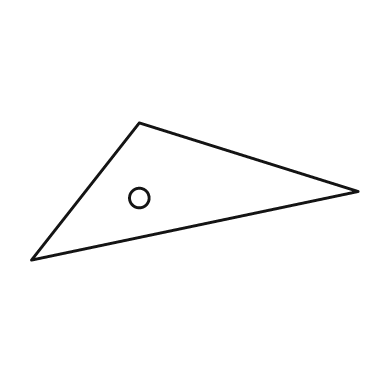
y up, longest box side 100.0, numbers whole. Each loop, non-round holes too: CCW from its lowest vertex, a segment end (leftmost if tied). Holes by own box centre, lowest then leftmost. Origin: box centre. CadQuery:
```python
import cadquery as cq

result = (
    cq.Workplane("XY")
    .moveTo(-50.0, -21.0)
    .lineTo(50.0, 0.0)
    .lineTo(-17.0, 21.0)
    .close()
    .moveTo(-17.0, -2.0)
    .circle(3.0)
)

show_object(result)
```